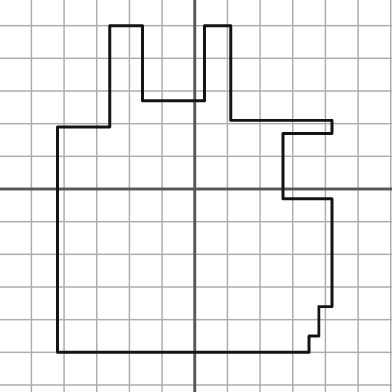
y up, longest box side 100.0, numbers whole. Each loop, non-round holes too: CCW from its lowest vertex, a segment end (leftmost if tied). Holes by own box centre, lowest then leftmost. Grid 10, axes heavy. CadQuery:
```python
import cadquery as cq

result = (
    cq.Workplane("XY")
    .moveTo(-42.0, -50.0)
    .lineTo(35.0, -50.0)
    .lineTo(35.0, -45.0)
    .lineTo(38.0, -45.0)
    .lineTo(38.0, -36.0)
    .lineTo(42.0, -36.0)
    .lineTo(42.0, -3.0)
    .lineTo(27.0, -3.0)
    .lineTo(27.0, 17.0)
    .lineTo(42.0, 17.0)
    .lineTo(42.0, 21.0)
    .lineTo(11.0, 21.0)
    .lineTo(11.0, 50.0)
    .lineTo(3.0, 50.0)
    .lineTo(3.0, 27.0)
    .lineTo(-16.0, 27.0)
    .lineTo(-16.0, 50.0)
    .lineTo(-26.0, 50.0)
    .lineTo(-26.0, 19.0)
    .lineTo(-42.0, 19.0)
    .close()
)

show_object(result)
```